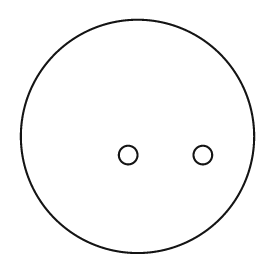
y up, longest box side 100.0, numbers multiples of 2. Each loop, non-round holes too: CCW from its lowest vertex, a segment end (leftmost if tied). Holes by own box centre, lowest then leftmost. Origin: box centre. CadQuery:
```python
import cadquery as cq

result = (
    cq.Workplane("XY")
    .moveTo(0.0, 0.0)
    .circle(50.0)
    .moveTo(-4.0, -8.0)
    .circle(4.0)
    .moveTo(28.0, -8.0)
    .circle(4.0)
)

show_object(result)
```